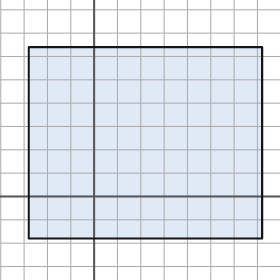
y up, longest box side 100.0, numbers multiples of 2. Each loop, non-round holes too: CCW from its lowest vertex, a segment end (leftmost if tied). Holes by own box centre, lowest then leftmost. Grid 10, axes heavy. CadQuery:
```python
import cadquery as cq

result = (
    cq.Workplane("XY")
    .moveTo(-28.0, -18.0)
    .lineTo(72.0, -18.0)
    .lineTo(72.0, 64.0)
    .lineTo(-28.0, 64.0)
    .close()
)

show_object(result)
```